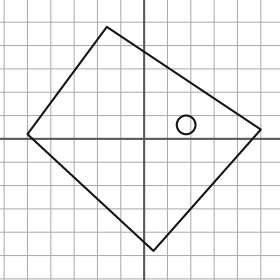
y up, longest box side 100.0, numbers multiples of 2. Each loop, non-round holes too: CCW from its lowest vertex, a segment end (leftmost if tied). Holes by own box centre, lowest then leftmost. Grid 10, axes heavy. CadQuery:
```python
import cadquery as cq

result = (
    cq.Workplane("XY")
    .moveTo(4.0, -48.0)
    .lineTo(50.0, 4.0)
    .lineTo(-16.0, 48.0)
    .lineTo(-50.0, 2.0)
    .close()
    .moveTo(18.0, 6.0)
    .circle(4.0)
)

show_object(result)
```